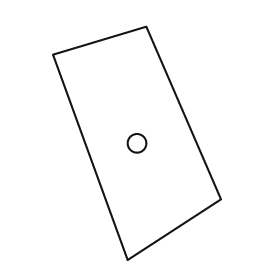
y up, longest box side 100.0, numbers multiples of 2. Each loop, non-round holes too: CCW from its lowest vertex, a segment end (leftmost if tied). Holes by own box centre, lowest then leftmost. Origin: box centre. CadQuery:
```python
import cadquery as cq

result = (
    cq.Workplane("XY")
    .moveTo(-4.0, -50.0)
    .lineTo(36.0, -24.0)
    .lineTo(4.0, 50.0)
    .lineTo(-36.0, 38.0)
    .close()
    .moveTo(0.0, 0.0)
    .circle(4.0)
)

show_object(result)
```